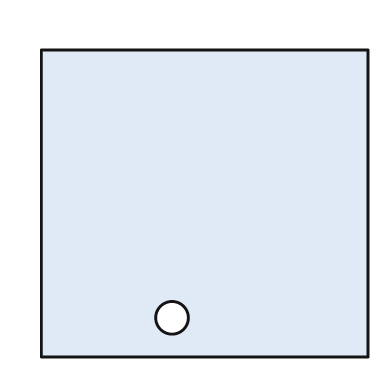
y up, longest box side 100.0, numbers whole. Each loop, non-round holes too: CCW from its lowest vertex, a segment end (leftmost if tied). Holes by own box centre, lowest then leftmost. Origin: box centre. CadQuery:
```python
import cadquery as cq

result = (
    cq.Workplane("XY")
    .moveTo(-50.0, -47.0)
    .lineTo(50.0, -47.0)
    .lineTo(50.0, 47.0)
    .lineTo(-50.0, 47.0)
    .close()
    .moveTo(-10.0, -35.0)
    .circle(5.0)
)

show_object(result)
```